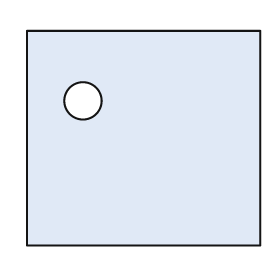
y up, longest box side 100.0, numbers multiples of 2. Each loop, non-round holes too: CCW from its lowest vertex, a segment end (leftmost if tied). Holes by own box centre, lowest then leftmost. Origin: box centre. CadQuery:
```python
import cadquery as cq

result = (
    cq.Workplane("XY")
    .moveTo(-50.0, -46.0)
    .lineTo(50.0, -46.0)
    .lineTo(50.0, 46.0)
    .lineTo(-50.0, 46.0)
    .close()
    .moveTo(-26.0, 16.0)
    .circle(8.0)
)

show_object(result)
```